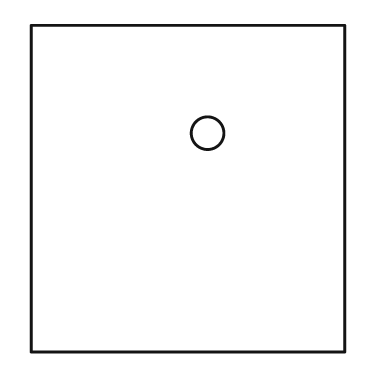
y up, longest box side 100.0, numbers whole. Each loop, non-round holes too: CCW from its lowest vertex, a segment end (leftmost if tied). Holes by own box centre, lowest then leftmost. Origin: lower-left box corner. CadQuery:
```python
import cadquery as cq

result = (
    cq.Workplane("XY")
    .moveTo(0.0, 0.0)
    .lineTo(96.0, 0.0)
    .lineTo(96.0, 100.0)
    .lineTo(0.0, 100.0)
    .close()
    .moveTo(54.0, 67.0)
    .circle(5.0)
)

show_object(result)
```